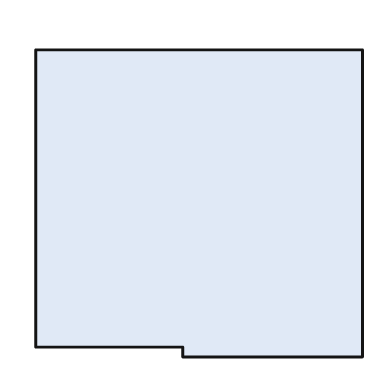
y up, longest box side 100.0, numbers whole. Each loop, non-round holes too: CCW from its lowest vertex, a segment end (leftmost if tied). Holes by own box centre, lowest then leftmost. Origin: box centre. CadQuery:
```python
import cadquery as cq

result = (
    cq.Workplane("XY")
    .moveTo(-5.0, -47.0)
    .lineTo(50.0, -47.0)
    .lineTo(50.0, 47.0)
    .lineTo(-50.0, 47.0)
    .lineTo(-50.0, -44.0)
    .lineTo(-5.0, -44.0)
    .close()
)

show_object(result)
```